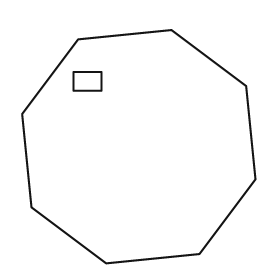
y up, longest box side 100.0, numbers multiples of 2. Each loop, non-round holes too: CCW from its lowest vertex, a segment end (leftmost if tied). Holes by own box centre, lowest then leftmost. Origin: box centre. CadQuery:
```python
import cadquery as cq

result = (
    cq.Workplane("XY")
    .moveTo(-14.0, -50.0)
    .lineTo(26.0, -46.0)
    .lineTo(50.0, -14.0)
    .lineTo(46.0, 26.0)
    .lineTo(14.0, 50.0)
    .lineTo(-26.0, 46.0)
    .lineTo(-50.0, 14.0)
    .lineTo(-46.0, -26.0)
    .close()
    .moveTo(-28.0, 24.0)
    .lineTo(-16.0, 24.0)
    .lineTo(-16.0, 32.0)
    .lineTo(-28.0, 32.0)
    .close()
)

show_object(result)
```